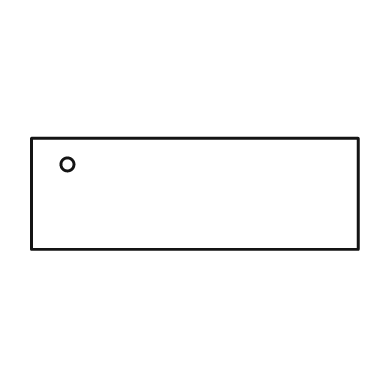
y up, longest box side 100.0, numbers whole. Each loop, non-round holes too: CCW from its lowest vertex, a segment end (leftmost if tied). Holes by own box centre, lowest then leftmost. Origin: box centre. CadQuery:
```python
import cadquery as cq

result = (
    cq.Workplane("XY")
    .moveTo(-50.0, -17.0)
    .lineTo(50.0, -17.0)
    .lineTo(50.0, 17.0)
    .lineTo(-50.0, 17.0)
    .close()
    .moveTo(-39.0, 9.0)
    .circle(2.0)
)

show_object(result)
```